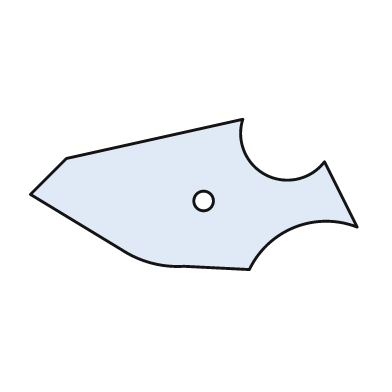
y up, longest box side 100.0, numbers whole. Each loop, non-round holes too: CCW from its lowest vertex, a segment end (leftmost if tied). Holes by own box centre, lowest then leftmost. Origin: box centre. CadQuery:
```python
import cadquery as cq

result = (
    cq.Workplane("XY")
    .moveTo(17.0, -23.0)
    .threePointArc((31.0, -10.0), (50.0, -10.0))
    .lineTo(40.0, 10.0)
    .threePointArc((22.0, 6.0), (15.0, 23.0))
    .lineTo(-39.0, 11.0)
    .lineTo(-50.0, 0.0)
    .lineTo(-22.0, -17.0)
    .threePointArc((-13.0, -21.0), (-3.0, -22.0))
    .close()
    .moveTo(3.0, -2.0)
    .circle(3.0)
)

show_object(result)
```